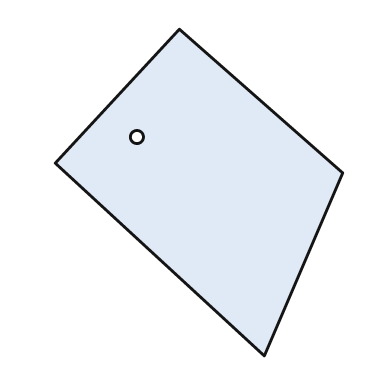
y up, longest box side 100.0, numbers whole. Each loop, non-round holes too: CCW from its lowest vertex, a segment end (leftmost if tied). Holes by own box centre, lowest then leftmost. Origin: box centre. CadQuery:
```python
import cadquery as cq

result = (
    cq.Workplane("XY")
    .moveTo(20.0, -50.0)
    .lineTo(44.0, 6.0)
    .lineTo(-6.0, 50.0)
    .lineTo(-44.0, 9.0)
    .close()
    .moveTo(-19.0, 17.0)
    .circle(2.0)
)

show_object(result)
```